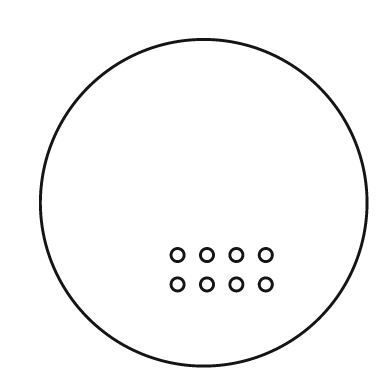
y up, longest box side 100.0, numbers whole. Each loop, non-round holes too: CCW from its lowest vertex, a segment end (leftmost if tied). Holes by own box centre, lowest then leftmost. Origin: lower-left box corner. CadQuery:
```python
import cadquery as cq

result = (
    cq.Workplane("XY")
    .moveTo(50.0, 50.0)
    .circle(50.0)
    .moveTo(42.0, 25.0)
    .circle(2.0)
    .moveTo(51.0, 25.0)
    .circle(2.0)
    .moveTo(60.0, 25.0)
    .circle(2.0)
    .moveTo(69.0, 25.0)
    .circle(2.0)
    .moveTo(42.0, 34.0)
    .circle(2.0)
    .moveTo(51.0, 34.0)
    .circle(2.0)
    .moveTo(60.0, 34.0)
    .circle(2.0)
    .moveTo(69.0, 34.0)
    .circle(2.0)
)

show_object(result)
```